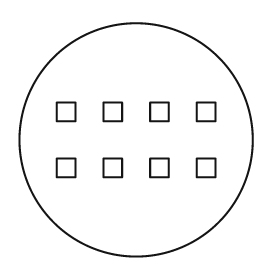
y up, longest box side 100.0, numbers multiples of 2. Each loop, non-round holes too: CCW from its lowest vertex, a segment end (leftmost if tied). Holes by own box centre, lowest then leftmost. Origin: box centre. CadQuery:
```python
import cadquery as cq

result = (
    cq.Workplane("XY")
    .moveTo(0.0, 0.0)
    .circle(50.0)
    .moveTo(-34.0, -16.0)
    .lineTo(-26.0, -16.0)
    .lineTo(-26.0, -8.0)
    .lineTo(-34.0, -8.0)
    .close()
    .moveTo(-14.0, -16.0)
    .lineTo(-6.0, -16.0)
    .lineTo(-6.0, -8.0)
    .lineTo(-14.0, -8.0)
    .close()
    .moveTo(6.0, -16.0)
    .lineTo(14.0, -16.0)
    .lineTo(14.0, -8.0)
    .lineTo(6.0, -8.0)
    .close()
    .moveTo(26.0, -16.0)
    .lineTo(34.0, -16.0)
    .lineTo(34.0, -8.0)
    .lineTo(26.0, -8.0)
    .close()
    .moveTo(-34.0, 8.0)
    .lineTo(-26.0, 8.0)
    .lineTo(-26.0, 16.0)
    .lineTo(-34.0, 16.0)
    .close()
    .moveTo(-14.0, 8.0)
    .lineTo(-6.0, 8.0)
    .lineTo(-6.0, 16.0)
    .lineTo(-14.0, 16.0)
    .close()
    .moveTo(6.0, 8.0)
    .lineTo(14.0, 8.0)
    .lineTo(14.0, 16.0)
    .lineTo(6.0, 16.0)
    .close()
    .moveTo(26.0, 8.0)
    .lineTo(34.0, 8.0)
    .lineTo(34.0, 16.0)
    .lineTo(26.0, 16.0)
    .close()
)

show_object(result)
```